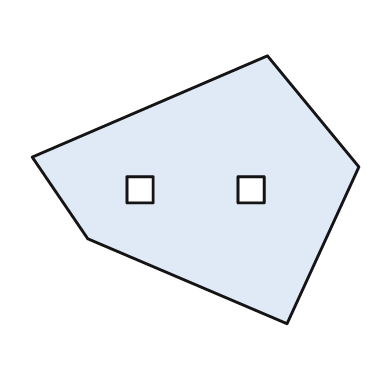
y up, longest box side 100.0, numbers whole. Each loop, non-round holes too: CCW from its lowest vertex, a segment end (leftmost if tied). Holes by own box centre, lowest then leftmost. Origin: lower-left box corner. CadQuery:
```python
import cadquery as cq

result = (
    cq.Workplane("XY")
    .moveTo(78.0, 0.0)
    .lineTo(100.0, 48.0)
    .lineTo(72.0, 82.0)
    .lineTo(0.0, 51.0)
    .lineTo(17.0, 26.0)
    .close()
    .moveTo(29.0, 37.0)
    .lineTo(37.0, 37.0)
    .lineTo(37.0, 45.0)
    .lineTo(29.0, 45.0)
    .close()
    .moveTo(63.0, 37.0)
    .lineTo(71.0, 37.0)
    .lineTo(71.0, 45.0)
    .lineTo(63.0, 45.0)
    .close()
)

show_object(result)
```